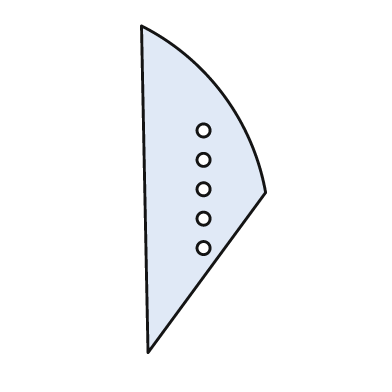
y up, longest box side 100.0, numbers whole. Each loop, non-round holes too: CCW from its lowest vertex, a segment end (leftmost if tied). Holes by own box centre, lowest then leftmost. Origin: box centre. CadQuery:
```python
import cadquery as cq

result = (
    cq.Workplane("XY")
    .moveTo(-17.0, -50.0)
    .lineTo(19.0, -1.0)
    .threePointArc((6.0, 29.0), (-19.0, 50.0))
    .close()
    .moveTo(0.0, -18.0)
    .circle(2.0)
    .moveTo(0.0, -9.0)
    .circle(2.0)
    .moveTo(0.0, 0.0)
    .circle(2.0)
    .moveTo(0.0, 9.0)
    .circle(2.0)
    .moveTo(0.0, 18.0)
    .circle(2.0)
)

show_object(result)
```